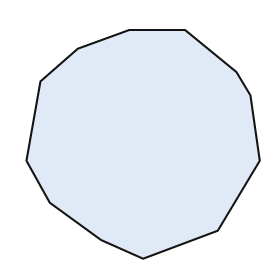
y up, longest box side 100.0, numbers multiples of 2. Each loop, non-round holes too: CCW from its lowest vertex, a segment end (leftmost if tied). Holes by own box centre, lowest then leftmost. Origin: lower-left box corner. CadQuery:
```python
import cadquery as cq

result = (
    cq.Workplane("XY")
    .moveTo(50.0, 0.0)
    .lineTo(82.0, 12.0)
    .lineTo(100.0, 42.0)
    .lineTo(96.0, 70.0)
    .lineTo(90.0, 80.0)
    .lineTo(68.0, 98.0)
    .lineTo(44.0, 98.0)
    .lineTo(22.0, 90.0)
    .lineTo(6.0, 76.0)
    .lineTo(0.0, 42.0)
    .lineTo(10.0, 24.0)
    .lineTo(32.0, 8.0)
    .close()
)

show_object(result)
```